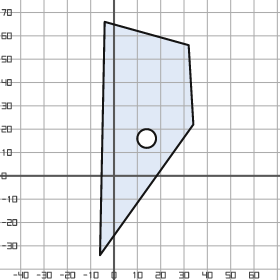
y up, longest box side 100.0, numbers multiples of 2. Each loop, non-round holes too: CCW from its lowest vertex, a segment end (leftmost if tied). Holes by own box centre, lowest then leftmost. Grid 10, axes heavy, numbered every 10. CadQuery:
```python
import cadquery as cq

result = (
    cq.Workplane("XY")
    .moveTo(-6.0, -34.0)
    .lineTo(34.0, 22.0)
    .lineTo(32.0, 56.0)
    .lineTo(-4.0, 66.0)
    .close()
    .moveTo(14.0, 16.0)
    .circle(4.0)
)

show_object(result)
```